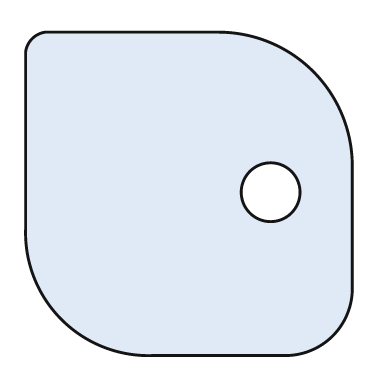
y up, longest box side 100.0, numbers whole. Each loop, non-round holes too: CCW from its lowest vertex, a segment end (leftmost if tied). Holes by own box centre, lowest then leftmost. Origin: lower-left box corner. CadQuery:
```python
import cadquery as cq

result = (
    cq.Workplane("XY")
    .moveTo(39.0, 0.0)
    .lineTo(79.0, 0.0)
    .threePointArc((94.0, 6.0), (100.0, 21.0))
    .lineTo(100.0, 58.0)
    .threePointArc((88.0, 87.0), (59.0, 99.0))
    .lineTo(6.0, 99.0)
    .threePointArc((2.0, 97.0), (0.0, 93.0))
    .lineTo(0.0, 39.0)
    .threePointArc((11.0, 11.0), (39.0, 0.0))
    .close()
    .moveTo(75.0, 50.0)
    .circle(9.0)
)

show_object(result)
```